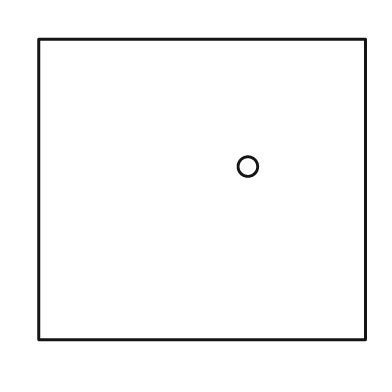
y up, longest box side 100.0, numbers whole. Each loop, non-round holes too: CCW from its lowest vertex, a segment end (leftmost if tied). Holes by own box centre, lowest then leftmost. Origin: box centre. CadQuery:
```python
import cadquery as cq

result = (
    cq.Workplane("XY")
    .moveTo(-50.0, -46.0)
    .lineTo(50.0, -46.0)
    .lineTo(50.0, 46.0)
    .lineTo(-50.0, 46.0)
    .close()
    .moveTo(14.0, 7.0)
    .circle(3.0)
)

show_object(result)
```